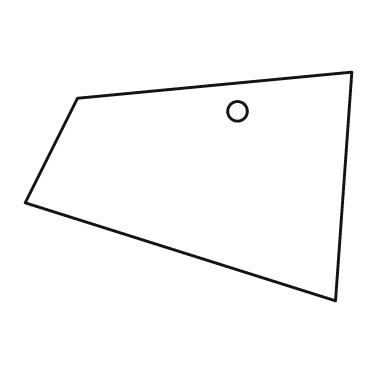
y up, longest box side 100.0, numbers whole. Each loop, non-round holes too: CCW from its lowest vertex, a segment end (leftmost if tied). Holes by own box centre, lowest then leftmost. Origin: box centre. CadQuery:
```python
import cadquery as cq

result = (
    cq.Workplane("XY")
    .moveTo(45.0, -35.0)
    .lineTo(50.0, 35.0)
    .lineTo(-34.0, 27.0)
    .lineTo(-50.0, -5.0)
    .close()
    .moveTo(15.0, 23.0)
    .circle(3.0)
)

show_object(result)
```